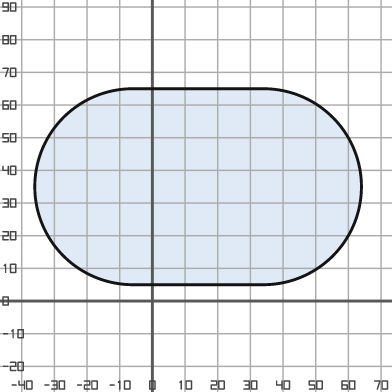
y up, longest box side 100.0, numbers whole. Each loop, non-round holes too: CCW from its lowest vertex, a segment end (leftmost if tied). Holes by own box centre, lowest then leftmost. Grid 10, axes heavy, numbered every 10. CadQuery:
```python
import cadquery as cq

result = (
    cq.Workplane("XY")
    .moveTo(-6.0, 5.0)
    .lineTo(34.0, 5.0)
    .threePointArc((64.0, 35.0), (34.0, 65.0))
    .lineTo(-6.0, 65.0)
    .threePointArc((-36.0, 35.0), (-6.0, 5.0))
    .close()
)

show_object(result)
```